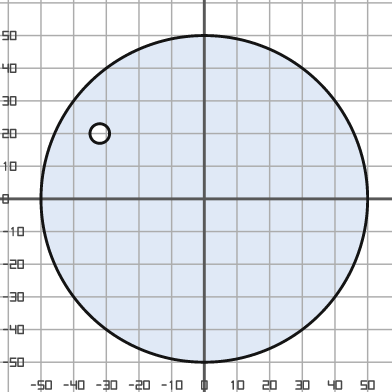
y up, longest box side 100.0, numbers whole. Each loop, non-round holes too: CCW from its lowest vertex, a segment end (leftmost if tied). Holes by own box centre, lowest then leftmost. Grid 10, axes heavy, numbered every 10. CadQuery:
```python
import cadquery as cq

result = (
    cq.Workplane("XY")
    .moveTo(0.0, 0.0)
    .circle(50.0)
    .moveTo(-32.0, 20.0)
    .circle(3.0)
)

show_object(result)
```